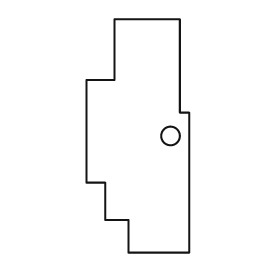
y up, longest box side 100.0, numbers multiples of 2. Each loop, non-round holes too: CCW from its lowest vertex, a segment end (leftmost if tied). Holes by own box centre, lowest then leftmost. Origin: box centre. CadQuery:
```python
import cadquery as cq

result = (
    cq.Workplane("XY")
    .moveTo(-4.0, -50.0)
    .lineTo(22.0, -50.0)
    .lineTo(22.0, 10.0)
    .lineTo(18.0, 10.0)
    .lineTo(18.0, 50.0)
    .lineTo(-10.0, 50.0)
    .lineTo(-10.0, 24.0)
    .lineTo(-22.0, 24.0)
    .lineTo(-22.0, -20.0)
    .lineTo(-14.0, -20.0)
    .lineTo(-14.0, -36.0)
    .lineTo(-4.0, -36.0)
    .close()
    .moveTo(14.0, 0.0)
    .circle(4.0)
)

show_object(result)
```